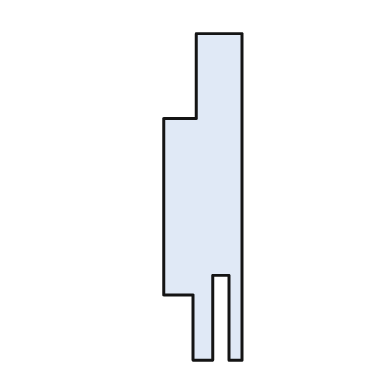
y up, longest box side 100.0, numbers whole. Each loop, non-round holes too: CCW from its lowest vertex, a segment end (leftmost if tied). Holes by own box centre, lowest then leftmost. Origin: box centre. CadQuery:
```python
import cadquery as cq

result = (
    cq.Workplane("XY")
    .moveTo(-3.0, -50.0)
    .lineTo(3.0, -50.0)
    .lineTo(3.0, -24.0)
    .lineTo(8.0, -24.0)
    .lineTo(8.0, -50.0)
    .lineTo(12.0, -50.0)
    .lineTo(12.0, 50.0)
    .lineTo(-2.0, 50.0)
    .lineTo(-2.0, 24.0)
    .lineTo(-12.0, 24.0)
    .lineTo(-12.0, -30.0)
    .lineTo(-3.0, -30.0)
    .close()
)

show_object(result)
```